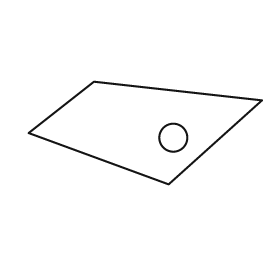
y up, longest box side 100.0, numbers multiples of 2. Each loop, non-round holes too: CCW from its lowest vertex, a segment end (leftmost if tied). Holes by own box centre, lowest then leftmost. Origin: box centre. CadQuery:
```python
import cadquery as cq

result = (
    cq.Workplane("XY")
    .moveTo(10.0, -22.0)
    .lineTo(50.0, 14.0)
    .lineTo(-22.0, 22.0)
    .lineTo(-50.0, 0.0)
    .close()
    .moveTo(12.0, -2.0)
    .circle(6.0)
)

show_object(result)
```